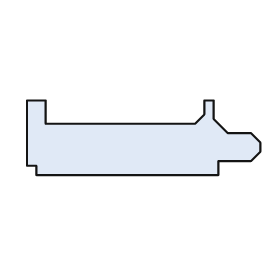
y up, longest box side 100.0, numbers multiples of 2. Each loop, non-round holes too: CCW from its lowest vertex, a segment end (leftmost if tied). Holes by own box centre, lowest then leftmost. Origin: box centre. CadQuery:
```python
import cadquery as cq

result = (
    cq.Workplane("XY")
    .moveTo(-46.0, -16.0)
    .lineTo(32.0, -16.0)
    .lineTo(32.0, -10.0)
    .lineTo(46.0, -10.0)
    .lineTo(50.0, -6.0)
    .lineTo(50.0, -2.0)
    .lineTo(46.0, 2.0)
    .lineTo(36.0, 2.0)
    .lineTo(30.0, 8.0)
    .lineTo(30.0, 16.0)
    .lineTo(26.0, 16.0)
    .lineTo(26.0, 10.0)
    .lineTo(22.0, 6.0)
    .lineTo(-42.0, 6.0)
    .lineTo(-42.0, 16.0)
    .lineTo(-50.0, 16.0)
    .lineTo(-50.0, -12.0)
    .lineTo(-46.0, -12.0)
    .close()
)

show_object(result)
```